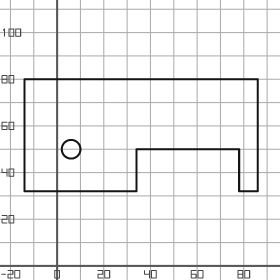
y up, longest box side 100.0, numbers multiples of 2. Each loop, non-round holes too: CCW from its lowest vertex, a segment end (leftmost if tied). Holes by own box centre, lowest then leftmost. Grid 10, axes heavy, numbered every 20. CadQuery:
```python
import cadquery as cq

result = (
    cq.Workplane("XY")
    .moveTo(-14.0, 32.0)
    .lineTo(34.0, 32.0)
    .lineTo(34.0, 50.0)
    .lineTo(78.0, 50.0)
    .lineTo(78.0, 32.0)
    .lineTo(86.0, 32.0)
    .lineTo(86.0, 80.0)
    .lineTo(-14.0, 80.0)
    .close()
    .moveTo(6.0, 50.0)
    .circle(4.0)
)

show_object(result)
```